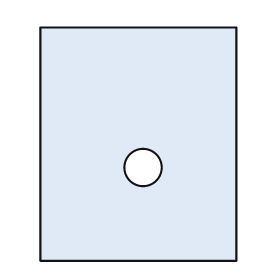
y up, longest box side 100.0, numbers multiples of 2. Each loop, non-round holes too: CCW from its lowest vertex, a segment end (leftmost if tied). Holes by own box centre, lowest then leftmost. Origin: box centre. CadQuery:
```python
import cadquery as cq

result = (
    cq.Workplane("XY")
    .moveTo(-42.0, -50.0)
    .lineTo(42.0, -50.0)
    .lineTo(42.0, 50.0)
    .lineTo(-42.0, 50.0)
    .close()
    .moveTo(2.0, -10.0)
    .circle(8.0)
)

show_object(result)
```